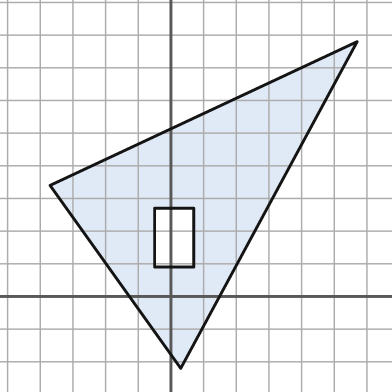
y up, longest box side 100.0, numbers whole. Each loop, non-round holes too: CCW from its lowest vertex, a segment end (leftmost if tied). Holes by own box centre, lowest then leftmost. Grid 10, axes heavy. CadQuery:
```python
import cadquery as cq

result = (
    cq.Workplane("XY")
    .moveTo(3.0, -22.0)
    .lineTo(57.0, 78.0)
    .lineTo(-37.0, 34.0)
    .close()
    .moveTo(-5.0, 9.0)
    .lineTo(7.0, 9.0)
    .lineTo(7.0, 27.0)
    .lineTo(-5.0, 27.0)
    .close()
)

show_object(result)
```